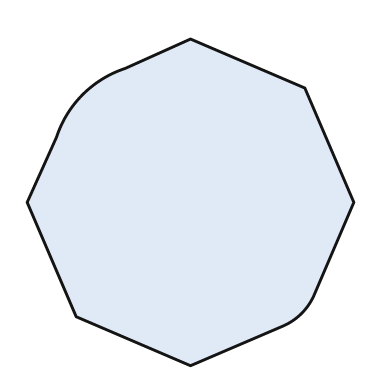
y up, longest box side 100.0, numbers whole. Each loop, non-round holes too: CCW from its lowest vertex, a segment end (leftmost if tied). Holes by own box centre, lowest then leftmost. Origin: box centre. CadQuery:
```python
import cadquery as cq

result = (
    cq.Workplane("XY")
    .moveTo(0.0, -50.0)
    .lineTo(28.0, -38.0)
    .threePointArc((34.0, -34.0), (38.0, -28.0))
    .lineTo(50.0, 0.0)
    .lineTo(35.0, 35.0)
    .lineTo(0.0, 50.0)
    .lineTo(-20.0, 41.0)
    .threePointArc((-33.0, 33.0), (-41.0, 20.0))
    .lineTo(-50.0, 0.0)
    .lineTo(-35.0, -35.0)
    .close()
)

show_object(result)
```